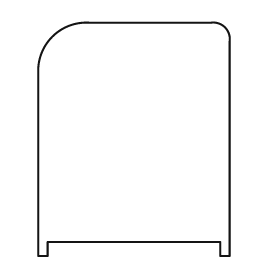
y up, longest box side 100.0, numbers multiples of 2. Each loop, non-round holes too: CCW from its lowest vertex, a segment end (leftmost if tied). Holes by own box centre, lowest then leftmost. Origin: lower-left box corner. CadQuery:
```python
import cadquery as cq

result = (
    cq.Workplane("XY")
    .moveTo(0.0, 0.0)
    .lineTo(4.0, 0.0)
    .lineTo(4.0, 6.0)
    .lineTo(78.0, 6.0)
    .lineTo(78.0, 0.0)
    .lineTo(82.0, 0.0)
    .lineTo(82.0, 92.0)
    .threePointArc((80.0, 98.0), (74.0, 100.0))
    .lineTo(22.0, 100.0)
    .threePointArc((6.0, 94.0), (0.0, 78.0))
    .close()
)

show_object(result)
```